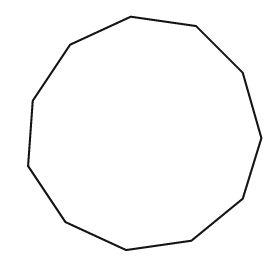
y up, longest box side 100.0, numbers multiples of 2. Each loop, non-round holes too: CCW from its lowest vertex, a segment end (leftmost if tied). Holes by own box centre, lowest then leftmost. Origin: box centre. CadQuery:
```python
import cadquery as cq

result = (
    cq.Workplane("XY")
    .moveTo(-8.0, -50.0)
    .lineTo(20.0, -46.0)
    .lineTo(42.0, -28.0)
    .lineTo(50.0, -2.0)
    .lineTo(42.0, 26.0)
    .lineTo(22.0, 46.0)
    .lineTo(-6.0, 50.0)
    .lineTo(-32.0, 38.0)
    .lineTo(-48.0, 14.0)
    .lineTo(-50.0, -14.0)
    .lineTo(-34.0, -38.0)
    .close()
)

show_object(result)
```